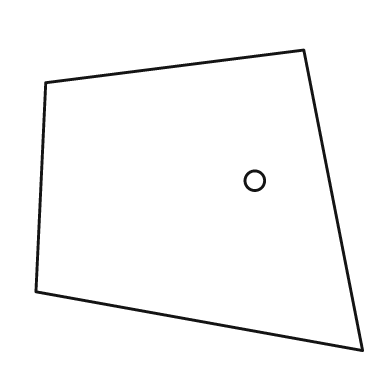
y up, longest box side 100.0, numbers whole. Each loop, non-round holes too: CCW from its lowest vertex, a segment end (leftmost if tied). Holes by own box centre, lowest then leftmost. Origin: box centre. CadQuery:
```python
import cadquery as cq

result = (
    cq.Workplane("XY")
    .moveTo(50.0, -46.0)
    .lineTo(32.0, 46.0)
    .lineTo(-47.0, 36.0)
    .lineTo(-50.0, -28.0)
    .close()
    .moveTo(17.0, 6.0)
    .circle(3.0)
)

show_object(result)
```